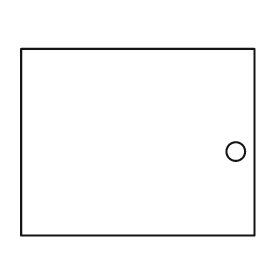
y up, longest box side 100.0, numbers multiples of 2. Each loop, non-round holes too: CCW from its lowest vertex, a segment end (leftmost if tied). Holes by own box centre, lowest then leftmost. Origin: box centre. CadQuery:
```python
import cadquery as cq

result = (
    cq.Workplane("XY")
    .moveTo(-50.0, -40.0)
    .lineTo(50.0, -40.0)
    .lineTo(50.0, 40.0)
    .lineTo(-50.0, 40.0)
    .close()
    .moveTo(42.0, -4.0)
    .circle(4.0)
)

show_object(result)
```